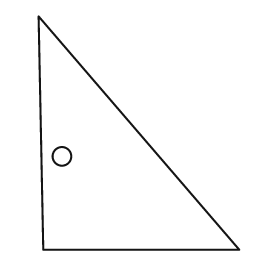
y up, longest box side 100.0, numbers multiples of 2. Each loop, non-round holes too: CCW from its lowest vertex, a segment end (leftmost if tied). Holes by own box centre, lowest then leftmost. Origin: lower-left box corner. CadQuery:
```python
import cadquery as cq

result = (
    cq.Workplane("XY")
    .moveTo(2.0, 0.0)
    .lineTo(86.0, 0.0)
    .lineTo(0.0, 100.0)
    .close()
    .moveTo(10.0, 40.0)
    .circle(4.0)
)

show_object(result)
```